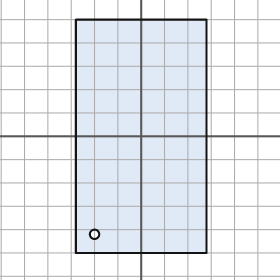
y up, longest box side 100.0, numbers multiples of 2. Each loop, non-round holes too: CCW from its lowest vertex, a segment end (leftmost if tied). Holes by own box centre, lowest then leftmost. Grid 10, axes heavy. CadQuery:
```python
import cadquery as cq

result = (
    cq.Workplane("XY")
    .moveTo(-28.0, -50.0)
    .lineTo(28.0, -50.0)
    .lineTo(28.0, 50.0)
    .lineTo(-28.0, 50.0)
    .close()
    .moveTo(-20.0, -42.0)
    .circle(2.0)
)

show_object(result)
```